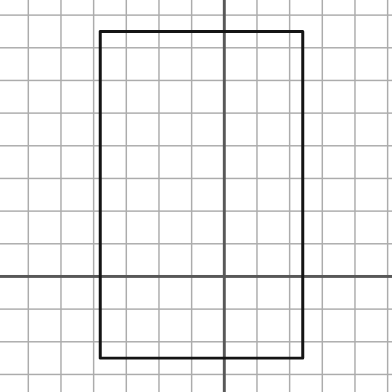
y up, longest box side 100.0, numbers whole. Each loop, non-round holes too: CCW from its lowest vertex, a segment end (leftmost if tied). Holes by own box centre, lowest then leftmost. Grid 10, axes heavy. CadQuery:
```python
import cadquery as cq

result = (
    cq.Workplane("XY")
    .moveTo(-38.0, -25.0)
    .lineTo(24.0, -25.0)
    .lineTo(24.0, 75.0)
    .lineTo(-38.0, 75.0)
    .close()
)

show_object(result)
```